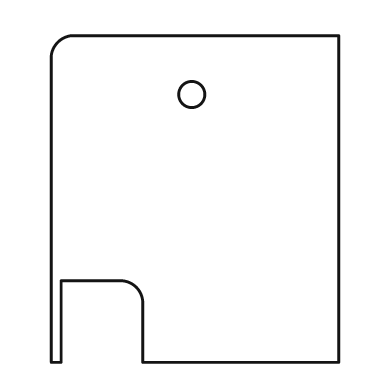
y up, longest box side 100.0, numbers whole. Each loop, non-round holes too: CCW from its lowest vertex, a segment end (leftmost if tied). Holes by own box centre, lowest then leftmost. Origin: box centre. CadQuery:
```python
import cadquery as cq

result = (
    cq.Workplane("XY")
    .moveTo(-44.0, -50.0)
    .lineTo(-41.0, -50.0)
    .lineTo(-41.0, -25.0)
    .lineTo(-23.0, -25.0)
    .threePointArc((-18.0, -27.0), (-16.0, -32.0))
    .lineTo(-16.0, -50.0)
    .lineTo(44.0, -50.0)
    .lineTo(44.0, 50.0)
    .lineTo(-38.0, 50.0)
    .threePointArc((-42.0, 48.0), (-44.0, 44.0))
    .close()
    .moveTo(-1.0, 32.0)
    .circle(4.0)
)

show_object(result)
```